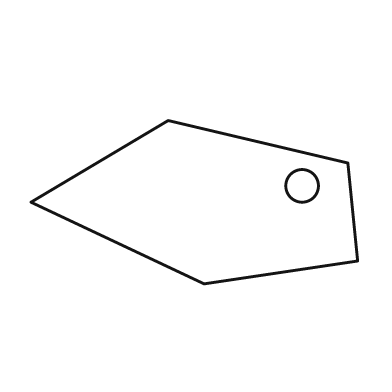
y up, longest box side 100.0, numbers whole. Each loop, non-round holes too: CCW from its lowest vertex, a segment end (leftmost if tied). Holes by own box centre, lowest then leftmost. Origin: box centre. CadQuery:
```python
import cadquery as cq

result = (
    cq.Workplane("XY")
    .moveTo(3.0, -25.0)
    .lineTo(50.0, -18.0)
    .lineTo(47.0, 12.0)
    .lineTo(-8.0, 25.0)
    .lineTo(-50.0, 0.0)
    .close()
    .moveTo(33.0, 5.0)
    .circle(5.0)
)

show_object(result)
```